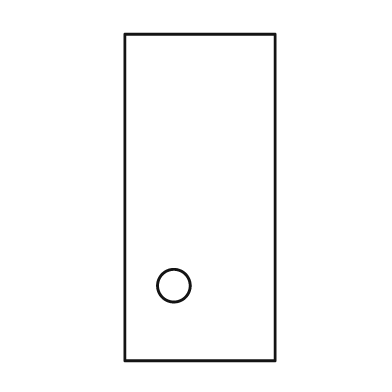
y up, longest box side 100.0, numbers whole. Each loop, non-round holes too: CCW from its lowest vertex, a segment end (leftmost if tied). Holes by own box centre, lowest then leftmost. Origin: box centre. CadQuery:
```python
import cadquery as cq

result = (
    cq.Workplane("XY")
    .moveTo(-23.0, -50.0)
    .lineTo(23.0, -50.0)
    .lineTo(23.0, 50.0)
    .lineTo(-23.0, 50.0)
    .close()
    .moveTo(-8.0, -27.0)
    .circle(5.0)
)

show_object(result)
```